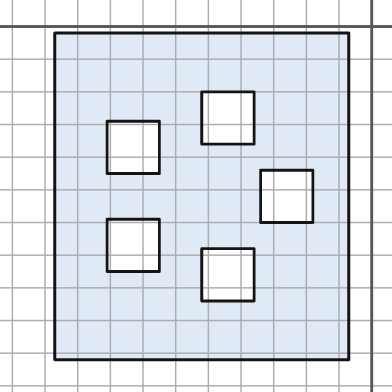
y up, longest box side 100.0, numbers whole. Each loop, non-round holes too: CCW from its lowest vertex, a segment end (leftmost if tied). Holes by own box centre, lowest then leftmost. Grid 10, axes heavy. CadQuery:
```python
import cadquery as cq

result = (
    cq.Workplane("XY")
    .moveTo(-97.0, -102.0)
    .lineTo(-7.0, -102.0)
    .lineTo(-7.0, -2.0)
    .lineTo(-97.0, -2.0)
    .close()
    .moveTo(-52.0, -84.0)
    .lineTo(-36.0, -84.0)
    .lineTo(-36.0, -68.0)
    .lineTo(-52.0, -68.0)
    .close()
    .moveTo(-81.0, -75.0)
    .lineTo(-65.0, -75.0)
    .lineTo(-65.0, -59.0)
    .lineTo(-81.0, -59.0)
    .close()
    .moveTo(-34.0, -60.0)
    .lineTo(-18.0, -60.0)
    .lineTo(-18.0, -44.0)
    .lineTo(-34.0, -44.0)
    .close()
    .moveTo(-81.0, -45.0)
    .lineTo(-65.0, -45.0)
    .lineTo(-65.0, -29.0)
    .lineTo(-81.0, -29.0)
    .close()
    .moveTo(-52.0, -36.0)
    .lineTo(-36.0, -36.0)
    .lineTo(-36.0, -20.0)
    .lineTo(-52.0, -20.0)
    .close()
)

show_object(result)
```